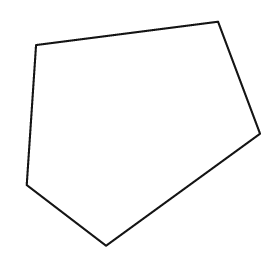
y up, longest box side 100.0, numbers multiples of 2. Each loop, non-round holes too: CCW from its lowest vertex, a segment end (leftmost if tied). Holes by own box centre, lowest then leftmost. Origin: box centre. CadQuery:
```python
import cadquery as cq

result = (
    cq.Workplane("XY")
    .moveTo(-16.0, -48.0)
    .lineTo(50.0, 0.0)
    .lineTo(32.0, 48.0)
    .lineTo(-46.0, 38.0)
    .lineTo(-50.0, -22.0)
    .close()
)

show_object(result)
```